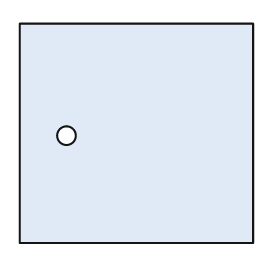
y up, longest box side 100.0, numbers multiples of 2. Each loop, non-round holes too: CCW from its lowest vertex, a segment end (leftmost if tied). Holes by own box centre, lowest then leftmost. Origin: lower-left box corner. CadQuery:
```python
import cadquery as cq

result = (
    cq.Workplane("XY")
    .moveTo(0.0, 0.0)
    .lineTo(100.0, 0.0)
    .lineTo(100.0, 94.0)
    .lineTo(0.0, 94.0)
    .close()
    .moveTo(20.0, 46.0)
    .circle(4.0)
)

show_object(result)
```